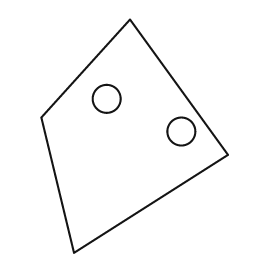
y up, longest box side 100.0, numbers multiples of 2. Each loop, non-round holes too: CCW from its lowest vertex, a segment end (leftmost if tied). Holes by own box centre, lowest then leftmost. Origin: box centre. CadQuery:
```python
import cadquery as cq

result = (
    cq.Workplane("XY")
    .moveTo(-26.0, -50.0)
    .lineTo(40.0, -8.0)
    .lineTo(-2.0, 50.0)
    .lineTo(-40.0, 8.0)
    .close()
    .moveTo(20.0, 2.0)
    .circle(6.0)
    .moveTo(-12.0, 16.0)
    .circle(6.0)
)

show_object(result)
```